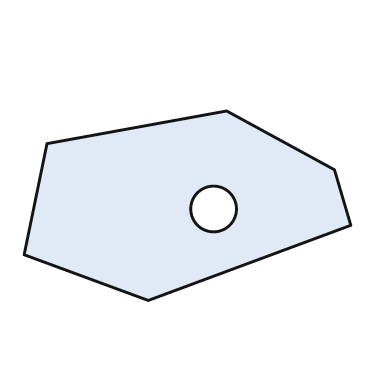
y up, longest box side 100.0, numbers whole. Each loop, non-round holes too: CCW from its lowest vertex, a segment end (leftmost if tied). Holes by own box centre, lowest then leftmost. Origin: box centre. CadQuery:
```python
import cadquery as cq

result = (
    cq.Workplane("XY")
    .moveTo(-12.0, -29.0)
    .lineTo(50.0, -6.0)
    .lineTo(45.0, 11.0)
    .lineTo(12.0, 29.0)
    .lineTo(-43.0, 19.0)
    .lineTo(-50.0, -15.0)
    .close()
    .moveTo(8.0, -1.0)
    .circle(7.0)
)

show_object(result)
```